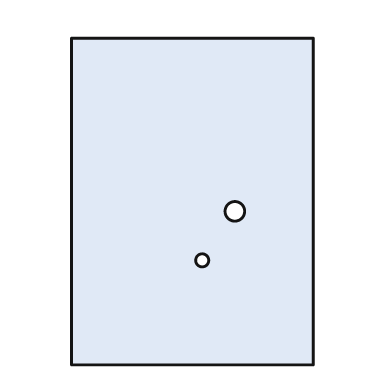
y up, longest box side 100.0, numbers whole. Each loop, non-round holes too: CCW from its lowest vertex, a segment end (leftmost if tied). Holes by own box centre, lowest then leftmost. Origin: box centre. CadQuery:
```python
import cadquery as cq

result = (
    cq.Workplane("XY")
    .moveTo(-37.0, -50.0)
    .lineTo(37.0, -50.0)
    .lineTo(37.0, 50.0)
    .lineTo(-37.0, 50.0)
    .close()
    .moveTo(3.0, -18.0)
    .circle(2.0)
    .moveTo(13.0, -3.0)
    .circle(3.0)
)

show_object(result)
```